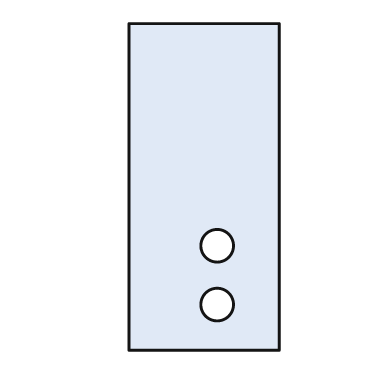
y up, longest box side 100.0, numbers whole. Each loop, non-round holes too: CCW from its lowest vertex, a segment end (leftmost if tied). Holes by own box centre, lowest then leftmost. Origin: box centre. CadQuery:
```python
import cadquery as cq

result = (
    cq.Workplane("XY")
    .moveTo(-23.0, -50.0)
    .lineTo(23.0, -50.0)
    .lineTo(23.0, 50.0)
    .lineTo(-23.0, 50.0)
    .close()
    .moveTo(4.0, -36.0)
    .circle(5.0)
    .moveTo(4.0, -18.0)
    .circle(5.0)
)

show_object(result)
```